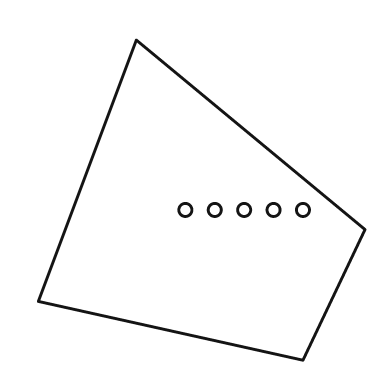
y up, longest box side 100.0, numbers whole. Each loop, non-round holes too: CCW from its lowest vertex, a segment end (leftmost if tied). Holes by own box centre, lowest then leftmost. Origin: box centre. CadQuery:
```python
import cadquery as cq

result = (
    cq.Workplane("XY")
    .moveTo(31.0, -49.0)
    .lineTo(50.0, -9.0)
    .lineTo(-20.0, 49.0)
    .lineTo(-50.0, -31.0)
    .close()
    .moveTo(-5.0, -3.0)
    .circle(2.0)
    .moveTo(4.0, -3.0)
    .circle(2.0)
    .moveTo(13.0, -3.0)
    .circle(2.0)
    .moveTo(22.0, -3.0)
    .circle(2.0)
    .moveTo(31.0, -3.0)
    .circle(2.0)
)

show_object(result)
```